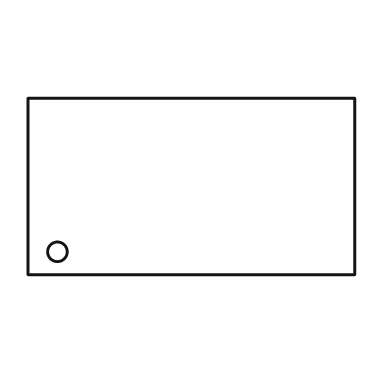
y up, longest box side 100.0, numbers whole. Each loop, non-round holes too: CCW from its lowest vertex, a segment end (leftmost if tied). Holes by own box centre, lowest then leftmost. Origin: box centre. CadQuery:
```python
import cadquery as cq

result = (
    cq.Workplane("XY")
    .moveTo(-50.0, -27.0)
    .lineTo(50.0, -27.0)
    .lineTo(50.0, 27.0)
    .lineTo(-50.0, 27.0)
    .close()
    .moveTo(-41.0, -20.0)
    .circle(3.0)
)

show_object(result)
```